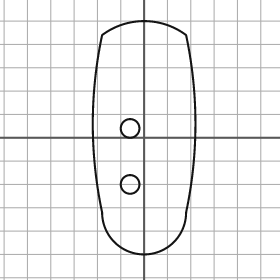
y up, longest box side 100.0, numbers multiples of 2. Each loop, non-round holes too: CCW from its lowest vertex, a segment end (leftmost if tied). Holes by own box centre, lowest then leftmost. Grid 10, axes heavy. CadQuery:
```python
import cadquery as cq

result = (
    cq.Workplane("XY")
    .moveTo(-18.0, -32.0)
    .threePointArc((0.0, -50.0), (18.0, -32.0))
    .threePointArc((22.0, 6.0), (18.0, 44.0))
    .threePointArc((0.0, 50.0), (-18.0, 44.0))
    .threePointArc((-22.0, 6.0), (-18.0, -32.0))
    .close()
    .moveTo(-6.0, -20.0)
    .circle(4.0)
    .moveTo(-6.0, 4.0)
    .circle(4.0)
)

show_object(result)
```